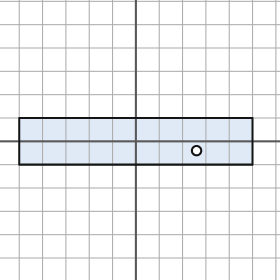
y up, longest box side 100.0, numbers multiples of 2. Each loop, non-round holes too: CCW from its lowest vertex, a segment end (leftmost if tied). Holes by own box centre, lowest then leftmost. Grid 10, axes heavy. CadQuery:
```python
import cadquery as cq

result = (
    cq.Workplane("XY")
    .moveTo(-50.0, -10.0)
    .lineTo(50.0, -10.0)
    .lineTo(50.0, 10.0)
    .lineTo(-50.0, 10.0)
    .close()
    .moveTo(26.0, -4.0)
    .circle(2.0)
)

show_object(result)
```